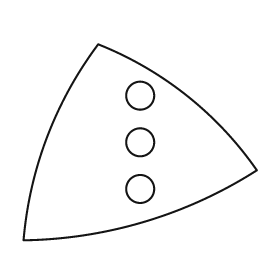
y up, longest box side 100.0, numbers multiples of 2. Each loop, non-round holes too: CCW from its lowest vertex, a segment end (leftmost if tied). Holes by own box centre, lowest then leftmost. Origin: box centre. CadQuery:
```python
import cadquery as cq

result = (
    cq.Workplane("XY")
    .moveTo(-50.0, -42.0)
    .threePointArc((2.0, -34.0), (50.0, -12.0))
    .threePointArc((20.0, 20.0), (-18.0, 42.0))
    .threePointArc((-40.0, 2.0), (-50.0, -42.0))
    .close()
    .moveTo(0.0, -20.0)
    .circle(6.0)
    .moveTo(0.0, 0.0)
    .circle(6.0)
    .moveTo(0.0, 20.0)
    .circle(6.0)
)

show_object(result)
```